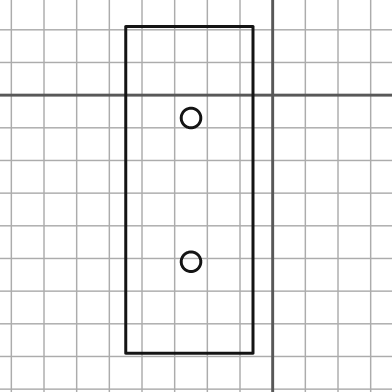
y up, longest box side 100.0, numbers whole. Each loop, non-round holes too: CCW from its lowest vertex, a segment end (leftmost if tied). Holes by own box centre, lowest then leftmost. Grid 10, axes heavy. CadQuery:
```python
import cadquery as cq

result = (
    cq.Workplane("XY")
    .moveTo(-45.0, -79.0)
    .lineTo(-6.0, -79.0)
    .lineTo(-6.0, 21.0)
    .lineTo(-45.0, 21.0)
    .close()
    .moveTo(-25.0, -51.0)
    .circle(3.0)
    .moveTo(-25.0, -7.0)
    .circle(3.0)
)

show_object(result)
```